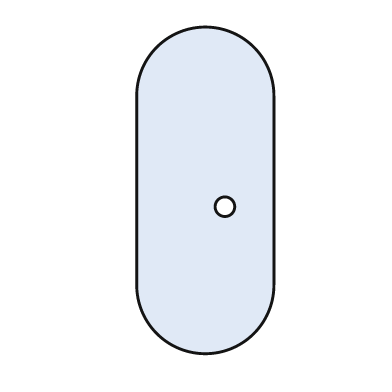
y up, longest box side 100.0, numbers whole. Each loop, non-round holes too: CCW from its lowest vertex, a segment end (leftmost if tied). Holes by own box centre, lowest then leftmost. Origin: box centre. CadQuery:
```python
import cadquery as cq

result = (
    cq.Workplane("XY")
    .moveTo(-21.0, -29.0)
    .threePointArc((0.0, -50.0), (21.0, -29.0))
    .lineTo(21.0, 29.0)
    .threePointArc((0.0, 50.0), (-21.0, 29.0))
    .close()
    .moveTo(6.0, -5.0)
    .circle(3.0)
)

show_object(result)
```